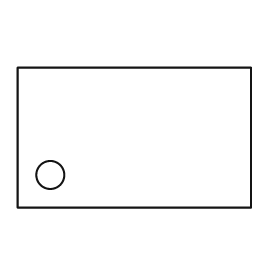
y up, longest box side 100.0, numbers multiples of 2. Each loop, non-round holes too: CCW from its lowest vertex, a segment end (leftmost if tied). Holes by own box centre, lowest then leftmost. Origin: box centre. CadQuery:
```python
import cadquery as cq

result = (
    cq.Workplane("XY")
    .moveTo(-50.0, -30.0)
    .lineTo(50.0, -30.0)
    .lineTo(50.0, 30.0)
    .lineTo(-50.0, 30.0)
    .close()
    .moveTo(-36.0, -16.0)
    .circle(6.0)
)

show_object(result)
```